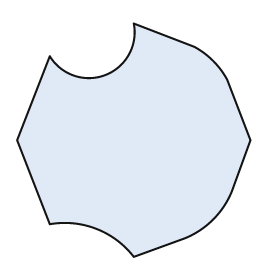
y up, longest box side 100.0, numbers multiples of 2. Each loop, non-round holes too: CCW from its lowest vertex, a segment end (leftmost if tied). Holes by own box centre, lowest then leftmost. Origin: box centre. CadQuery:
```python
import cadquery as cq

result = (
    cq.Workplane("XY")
    .moveTo(0.0, -50.0)
    .lineTo(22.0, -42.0)
    .threePointArc((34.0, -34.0), (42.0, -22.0))
    .lineTo(50.0, 0.0)
    .lineTo(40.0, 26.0)
    .threePointArc((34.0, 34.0), (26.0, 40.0))
    .lineTo(0.0, 50.0)
    .threePointArc((-12.0, 28.0), (-36.0, 36.0))
    .lineTo(-50.0, 0.0)
    .lineTo(-36.0, -36.0)
    .threePointArc((-16.0, -38.0), (0.0, -50.0))
    .close()
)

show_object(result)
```